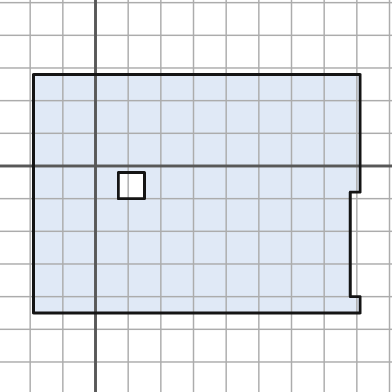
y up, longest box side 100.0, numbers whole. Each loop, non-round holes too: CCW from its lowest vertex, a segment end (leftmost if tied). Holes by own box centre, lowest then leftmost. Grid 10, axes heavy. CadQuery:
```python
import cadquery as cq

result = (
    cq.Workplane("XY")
    .moveTo(-19.0, -45.0)
    .lineTo(81.0, -45.0)
    .lineTo(81.0, -40.0)
    .lineTo(78.0, -40.0)
    .lineTo(78.0, -8.0)
    .lineTo(81.0, -8.0)
    .lineTo(81.0, 28.0)
    .lineTo(-19.0, 28.0)
    .close()
    .moveTo(7.0, -10.0)
    .lineTo(15.0, -10.0)
    .lineTo(15.0, -2.0)
    .lineTo(7.0, -2.0)
    .close()
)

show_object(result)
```